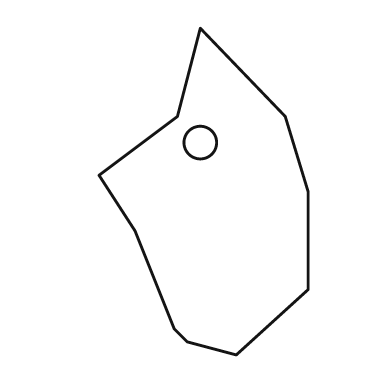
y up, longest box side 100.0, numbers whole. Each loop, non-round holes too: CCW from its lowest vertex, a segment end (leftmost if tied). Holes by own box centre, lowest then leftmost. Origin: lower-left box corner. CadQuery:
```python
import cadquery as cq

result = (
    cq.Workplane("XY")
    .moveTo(42.0, 0.0)
    .lineTo(64.0, 20.0)
    .lineTo(64.0, 50.0)
    .lineTo(57.0, 73.0)
    .lineTo(31.0, 100.0)
    .lineTo(24.0, 73.0)
    .lineTo(0.0, 55.0)
    .lineTo(11.0, 38.0)
    .lineTo(23.0, 8.0)
    .lineTo(27.0, 4.0)
    .close()
    .moveTo(31.0, 65.0)
    .circle(5.0)
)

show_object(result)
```